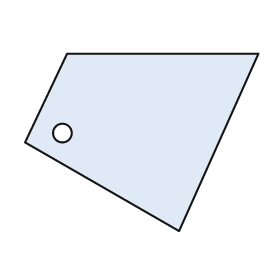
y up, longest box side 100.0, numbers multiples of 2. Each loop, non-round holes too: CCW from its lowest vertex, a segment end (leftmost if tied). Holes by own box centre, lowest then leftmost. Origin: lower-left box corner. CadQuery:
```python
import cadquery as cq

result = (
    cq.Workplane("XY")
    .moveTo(66.0, 0.0)
    .lineTo(100.0, 76.0)
    .lineTo(18.0, 76.0)
    .lineTo(0.0, 38.0)
    .close()
    .moveTo(16.0, 42.0)
    .circle(4.0)
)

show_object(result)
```